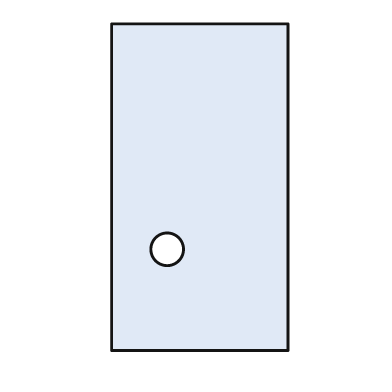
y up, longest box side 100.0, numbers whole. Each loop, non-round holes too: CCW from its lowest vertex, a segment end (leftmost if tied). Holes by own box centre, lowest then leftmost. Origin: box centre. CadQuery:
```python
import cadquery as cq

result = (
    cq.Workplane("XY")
    .moveTo(-27.0, -50.0)
    .lineTo(27.0, -50.0)
    .lineTo(27.0, 50.0)
    .lineTo(-27.0, 50.0)
    .close()
    .moveTo(-10.0, -19.0)
    .circle(5.0)
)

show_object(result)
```